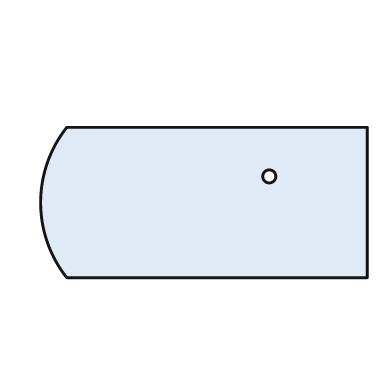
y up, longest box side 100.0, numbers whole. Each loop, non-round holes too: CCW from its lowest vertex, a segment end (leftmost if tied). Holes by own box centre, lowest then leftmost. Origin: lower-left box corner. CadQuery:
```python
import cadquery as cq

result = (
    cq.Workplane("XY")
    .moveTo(8.0, 0.0)
    .lineTo(100.0, 0.0)
    .lineTo(100.0, 46.0)
    .lineTo(8.0, 46.0)
    .threePointArc((0.0, 23.0), (8.0, 0.0))
    .close()
    .moveTo(70.0, 31.0)
    .circle(2.0)
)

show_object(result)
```